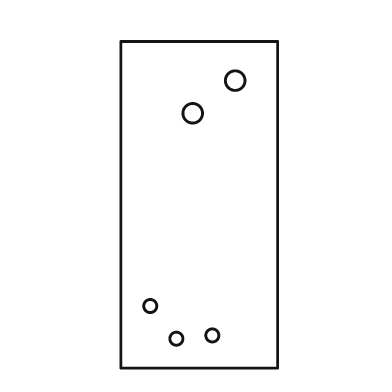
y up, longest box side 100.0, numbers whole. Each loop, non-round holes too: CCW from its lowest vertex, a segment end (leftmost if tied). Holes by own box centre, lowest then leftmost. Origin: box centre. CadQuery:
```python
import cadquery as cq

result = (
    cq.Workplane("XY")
    .moveTo(-24.0, -50.0)
    .lineTo(24.0, -50.0)
    .lineTo(24.0, 50.0)
    .lineTo(-24.0, 50.0)
    .close()
    .moveTo(-7.0, -41.0)
    .circle(2.0)
    .moveTo(4.0, -40.0)
    .circle(2.0)
    .moveTo(-15.0, -31.0)
    .circle(2.0)
    .moveTo(-2.0, 28.0)
    .circle(3.0)
    .moveTo(11.0, 38.0)
    .circle(3.0)
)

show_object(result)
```